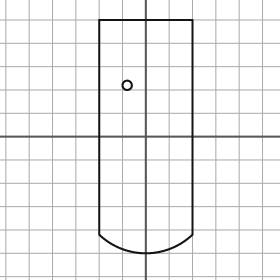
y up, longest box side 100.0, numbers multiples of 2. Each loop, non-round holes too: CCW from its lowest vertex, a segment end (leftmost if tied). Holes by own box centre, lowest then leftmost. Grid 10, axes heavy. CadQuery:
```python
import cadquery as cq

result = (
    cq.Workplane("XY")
    .moveTo(-20.0, -42.0)
    .threePointArc((0.0, -50.0), (20.0, -42.0))
    .lineTo(20.0, 50.0)
    .lineTo(-20.0, 50.0)
    .close()
    .moveTo(-8.0, 22.0)
    .circle(2.0)
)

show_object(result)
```